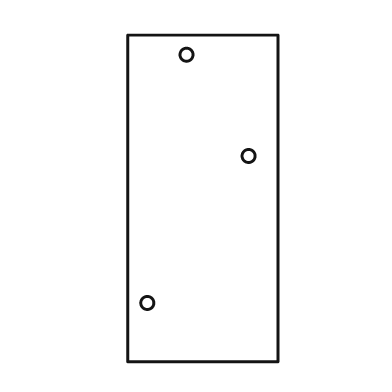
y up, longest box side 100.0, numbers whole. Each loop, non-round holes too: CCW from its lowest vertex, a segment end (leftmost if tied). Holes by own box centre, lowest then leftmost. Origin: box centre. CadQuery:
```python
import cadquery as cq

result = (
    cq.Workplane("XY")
    .moveTo(-23.0, -50.0)
    .lineTo(23.0, -50.0)
    .lineTo(23.0, 50.0)
    .lineTo(-23.0, 50.0)
    .close()
    .moveTo(-17.0, -32.0)
    .circle(2.0)
    .moveTo(14.0, 13.0)
    .circle(2.0)
    .moveTo(-5.0, 44.0)
    .circle(2.0)
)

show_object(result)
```